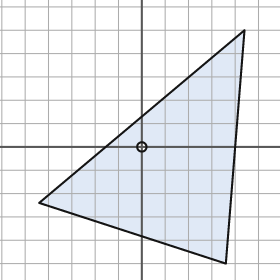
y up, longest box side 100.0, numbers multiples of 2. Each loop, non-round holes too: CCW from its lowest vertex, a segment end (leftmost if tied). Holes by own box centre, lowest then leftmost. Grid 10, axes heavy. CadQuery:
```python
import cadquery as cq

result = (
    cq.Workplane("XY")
    .moveTo(36.0, -50.0)
    .lineTo(44.0, 50.0)
    .lineTo(-44.0, -24.0)
    .close()
    .moveTo(0.0, 0.0)
    .circle(2.0)
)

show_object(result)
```